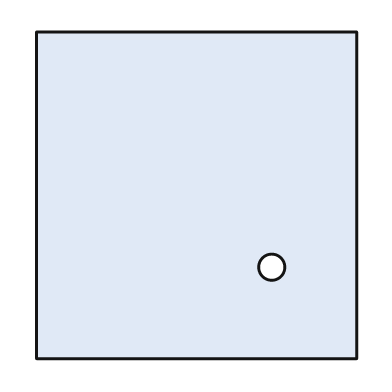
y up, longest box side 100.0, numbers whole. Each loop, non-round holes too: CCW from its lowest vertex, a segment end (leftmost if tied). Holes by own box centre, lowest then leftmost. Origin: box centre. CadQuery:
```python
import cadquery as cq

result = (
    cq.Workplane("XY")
    .moveTo(-49.0, -50.0)
    .lineTo(49.0, -50.0)
    .lineTo(49.0, 50.0)
    .lineTo(-49.0, 50.0)
    .close()
    .moveTo(23.0, -22.0)
    .circle(4.0)
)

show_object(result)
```